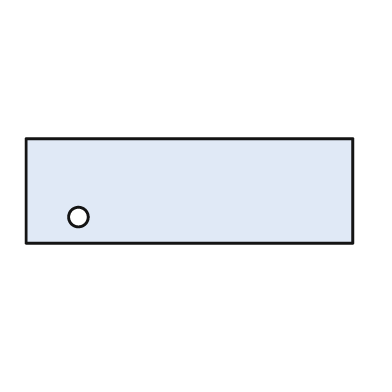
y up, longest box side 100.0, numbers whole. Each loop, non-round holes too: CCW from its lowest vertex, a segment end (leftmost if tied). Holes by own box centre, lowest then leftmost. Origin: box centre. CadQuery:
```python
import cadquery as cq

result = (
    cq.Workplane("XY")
    .moveTo(-50.0, -16.0)
    .lineTo(50.0, -16.0)
    .lineTo(50.0, 16.0)
    .lineTo(-50.0, 16.0)
    .close()
    .moveTo(-34.0, -8.0)
    .circle(3.0)
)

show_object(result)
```